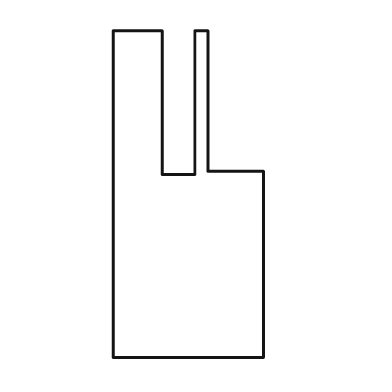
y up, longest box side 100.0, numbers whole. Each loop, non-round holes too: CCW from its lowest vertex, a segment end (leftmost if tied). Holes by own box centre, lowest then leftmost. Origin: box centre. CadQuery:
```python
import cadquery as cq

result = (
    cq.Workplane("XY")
    .moveTo(-23.0, -50.0)
    .lineTo(23.0, -50.0)
    .lineTo(23.0, 7.0)
    .lineTo(6.0, 7.0)
    .lineTo(6.0, 50.0)
    .lineTo(2.0, 50.0)
    .lineTo(2.0, 6.0)
    .lineTo(-8.0, 6.0)
    .lineTo(-8.0, 50.0)
    .lineTo(-23.0, 50.0)
    .close()
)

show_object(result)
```